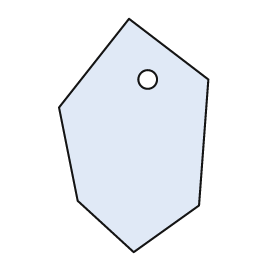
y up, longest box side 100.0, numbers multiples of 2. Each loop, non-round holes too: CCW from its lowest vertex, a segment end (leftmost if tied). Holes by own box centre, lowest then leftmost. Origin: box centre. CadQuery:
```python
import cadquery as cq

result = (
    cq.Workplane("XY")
    .moveTo(0.0, -50.0)
    .lineTo(28.0, -30.0)
    .lineTo(32.0, 24.0)
    .lineTo(-2.0, 50.0)
    .lineTo(-32.0, 12.0)
    .lineTo(-24.0, -28.0)
    .close()
    .moveTo(6.0, 24.0)
    .circle(4.0)
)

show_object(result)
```